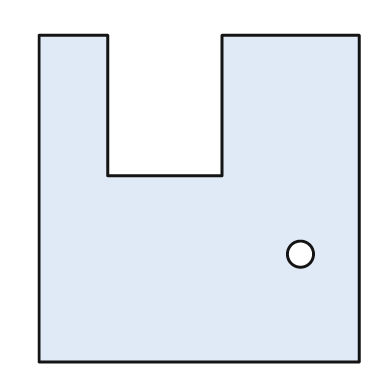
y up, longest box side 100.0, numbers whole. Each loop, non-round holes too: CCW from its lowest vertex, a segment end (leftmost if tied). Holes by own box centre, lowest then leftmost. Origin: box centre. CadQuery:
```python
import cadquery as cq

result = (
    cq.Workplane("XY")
    .moveTo(-49.0, -50.0)
    .lineTo(49.0, -50.0)
    .lineTo(49.0, 50.0)
    .lineTo(7.0, 50.0)
    .lineTo(7.0, 7.0)
    .lineTo(-28.0, 7.0)
    .lineTo(-28.0, 50.0)
    .lineTo(-49.0, 50.0)
    .close()
    .moveTo(31.0, -17.0)
    .circle(4.0)
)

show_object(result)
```